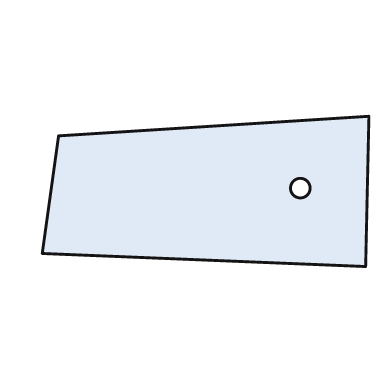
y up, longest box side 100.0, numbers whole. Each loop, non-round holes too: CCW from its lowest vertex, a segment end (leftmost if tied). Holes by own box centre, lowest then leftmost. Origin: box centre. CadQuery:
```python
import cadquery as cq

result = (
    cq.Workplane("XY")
    .moveTo(49.0, -23.0)
    .lineTo(50.0, 23.0)
    .lineTo(-45.0, 17.0)
    .lineTo(-50.0, -19.0)
    .close()
    .moveTo(29.0, 1.0)
    .circle(3.0)
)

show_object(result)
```